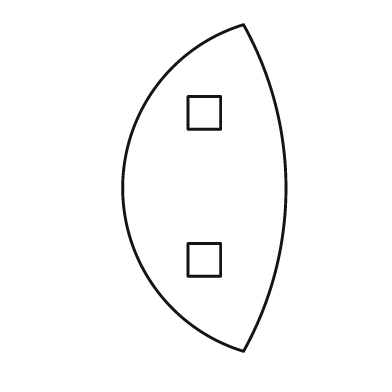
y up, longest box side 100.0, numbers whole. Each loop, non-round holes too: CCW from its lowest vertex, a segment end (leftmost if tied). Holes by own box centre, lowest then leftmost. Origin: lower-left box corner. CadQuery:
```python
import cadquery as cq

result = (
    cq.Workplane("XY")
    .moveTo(37.0, 0.0)
    .threePointArc((50.0, 50.0), (37.0, 100.0))
    .threePointArc((0.0, 50.0), (37.0, 0.0))
    .close()
    .moveTo(20.0, 23.0)
    .lineTo(30.0, 23.0)
    .lineTo(30.0, 33.0)
    .lineTo(20.0, 33.0)
    .close()
    .moveTo(20.0, 68.0)
    .lineTo(30.0, 68.0)
    .lineTo(30.0, 78.0)
    .lineTo(20.0, 78.0)
    .close()
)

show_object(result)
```